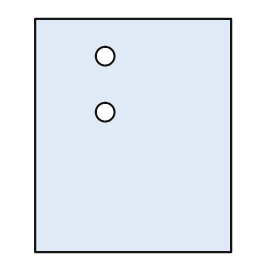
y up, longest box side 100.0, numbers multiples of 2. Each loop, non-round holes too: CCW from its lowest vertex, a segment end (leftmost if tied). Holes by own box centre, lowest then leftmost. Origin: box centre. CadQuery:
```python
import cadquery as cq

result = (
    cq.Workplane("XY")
    .moveTo(-42.0, -50.0)
    .lineTo(42.0, -50.0)
    .lineTo(42.0, 50.0)
    .lineTo(-42.0, 50.0)
    .close()
    .moveTo(-12.0, 10.0)
    .circle(4.0)
    .moveTo(-12.0, 34.0)
    .circle(4.0)
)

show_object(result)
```